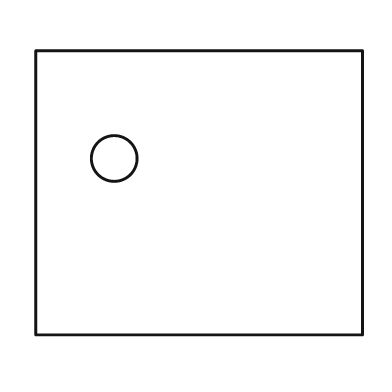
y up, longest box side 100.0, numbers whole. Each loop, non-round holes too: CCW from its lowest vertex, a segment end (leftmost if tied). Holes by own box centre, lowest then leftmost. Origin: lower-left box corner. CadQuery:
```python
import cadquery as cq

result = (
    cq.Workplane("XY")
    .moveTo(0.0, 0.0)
    .lineTo(100.0, 0.0)
    .lineTo(100.0, 87.0)
    .lineTo(0.0, 87.0)
    .close()
    .moveTo(24.0, 54.0)
    .circle(7.0)
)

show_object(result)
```